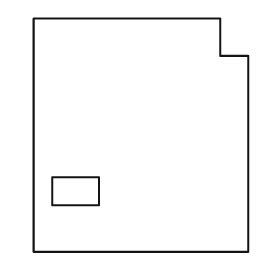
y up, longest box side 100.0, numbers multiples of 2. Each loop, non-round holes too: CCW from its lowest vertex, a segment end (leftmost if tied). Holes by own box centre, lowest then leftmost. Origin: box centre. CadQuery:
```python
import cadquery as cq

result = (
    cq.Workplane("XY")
    .moveTo(-46.0, -50.0)
    .lineTo(46.0, -50.0)
    .lineTo(46.0, 34.0)
    .lineTo(34.0, 34.0)
    .lineTo(34.0, 50.0)
    .lineTo(-46.0, 50.0)
    .close()
    .moveTo(-38.0, -30.0)
    .lineTo(-18.0, -30.0)
    .lineTo(-18.0, -18.0)
    .lineTo(-38.0, -18.0)
    .close()
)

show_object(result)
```